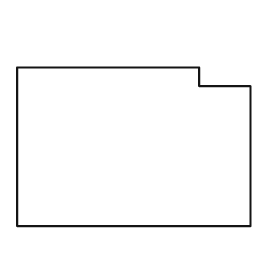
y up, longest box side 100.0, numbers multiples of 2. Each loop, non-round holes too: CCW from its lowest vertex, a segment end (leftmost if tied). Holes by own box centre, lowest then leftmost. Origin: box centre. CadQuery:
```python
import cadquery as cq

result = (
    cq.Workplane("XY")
    .moveTo(-50.0, -34.0)
    .lineTo(50.0, -34.0)
    .lineTo(50.0, 26.0)
    .lineTo(28.0, 26.0)
    .lineTo(28.0, 34.0)
    .lineTo(-50.0, 34.0)
    .close()
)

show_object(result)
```